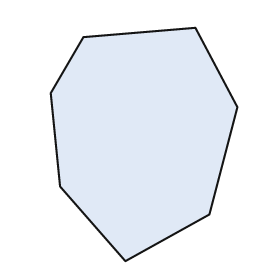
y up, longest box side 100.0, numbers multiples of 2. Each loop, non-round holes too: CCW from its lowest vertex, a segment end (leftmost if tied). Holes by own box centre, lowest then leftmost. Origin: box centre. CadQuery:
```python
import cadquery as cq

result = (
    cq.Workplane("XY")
    .moveTo(-8.0, -50.0)
    .lineTo(28.0, -30.0)
    .lineTo(40.0, 16.0)
    .lineTo(22.0, 50.0)
    .lineTo(-26.0, 46.0)
    .lineTo(-40.0, 22.0)
    .lineTo(-36.0, -18.0)
    .close()
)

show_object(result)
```